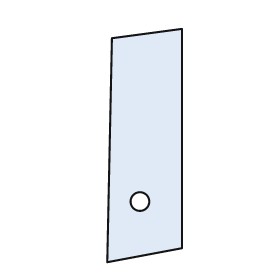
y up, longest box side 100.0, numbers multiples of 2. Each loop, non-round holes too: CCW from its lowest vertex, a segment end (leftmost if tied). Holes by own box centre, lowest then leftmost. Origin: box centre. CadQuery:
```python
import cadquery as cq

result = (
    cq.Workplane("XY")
    .moveTo(-16.0, -50.0)
    .lineTo(16.0, -44.0)
    .lineTo(16.0, 50.0)
    .lineTo(-14.0, 46.0)
    .close()
    .moveTo(-2.0, -24.0)
    .circle(4.0)
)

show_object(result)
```